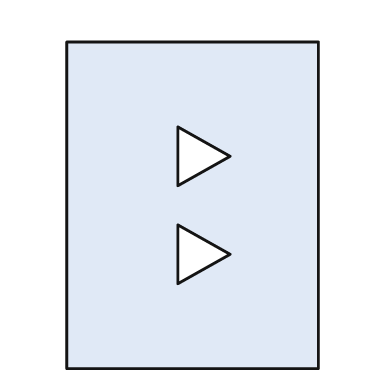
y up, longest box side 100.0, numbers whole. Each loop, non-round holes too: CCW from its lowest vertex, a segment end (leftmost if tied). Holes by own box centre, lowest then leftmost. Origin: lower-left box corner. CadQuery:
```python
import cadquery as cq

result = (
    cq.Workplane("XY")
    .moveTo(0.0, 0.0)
    .lineTo(77.0, 0.0)
    .lineTo(77.0, 100.0)
    .lineTo(0.0, 100.0)
    .close()
    .moveTo(34.0, 26.0)
    .lineTo(50.0, 35.0)
    .lineTo(34.0, 44.0)
    .close()
    .moveTo(34.0, 56.0)
    .lineTo(50.0, 65.0)
    .lineTo(34.0, 74.0)
    .close()
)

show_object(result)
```